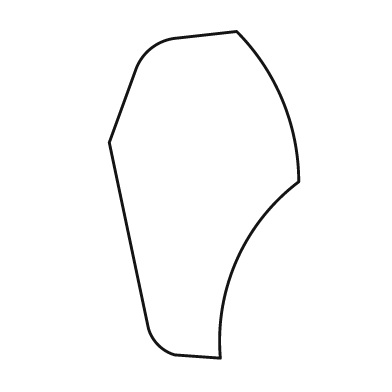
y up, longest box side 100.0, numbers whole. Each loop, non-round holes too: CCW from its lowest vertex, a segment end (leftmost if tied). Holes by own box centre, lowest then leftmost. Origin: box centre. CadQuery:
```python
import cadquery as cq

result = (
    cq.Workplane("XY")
    .moveTo(5.0, -50.0)
    .threePointArc((10.0, -20.0), (29.0, 4.0))
    .threePointArc((24.0, 29.0), (10.0, 50.0))
    .lineTo(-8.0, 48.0)
    .threePointArc((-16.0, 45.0), (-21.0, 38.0))
    .lineTo(-29.0, 16.0)
    .lineTo(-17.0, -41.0)
    .threePointArc((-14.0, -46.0), (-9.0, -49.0))
    .close()
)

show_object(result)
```